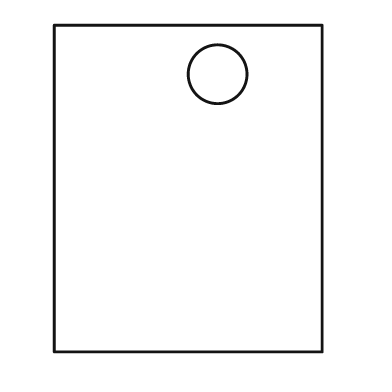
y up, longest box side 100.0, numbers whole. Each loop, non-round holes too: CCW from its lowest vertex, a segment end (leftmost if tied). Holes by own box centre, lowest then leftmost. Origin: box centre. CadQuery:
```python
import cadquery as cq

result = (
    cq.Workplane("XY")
    .moveTo(-41.0, -50.0)
    .lineTo(41.0, -50.0)
    .lineTo(41.0, 50.0)
    .lineTo(-41.0, 50.0)
    .close()
    .moveTo(9.0, 35.0)
    .circle(9.0)
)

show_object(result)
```